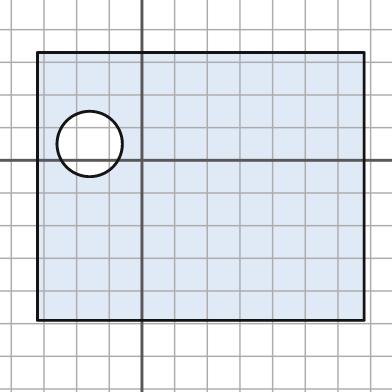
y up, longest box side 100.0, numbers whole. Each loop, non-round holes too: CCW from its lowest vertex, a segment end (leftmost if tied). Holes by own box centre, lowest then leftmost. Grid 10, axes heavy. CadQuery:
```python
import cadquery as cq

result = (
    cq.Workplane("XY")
    .moveTo(-32.0, -49.0)
    .lineTo(68.0, -49.0)
    .lineTo(68.0, 33.0)
    .lineTo(-32.0, 33.0)
    .close()
    .moveTo(-16.0, 5.0)
    .circle(10.0)
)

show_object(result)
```